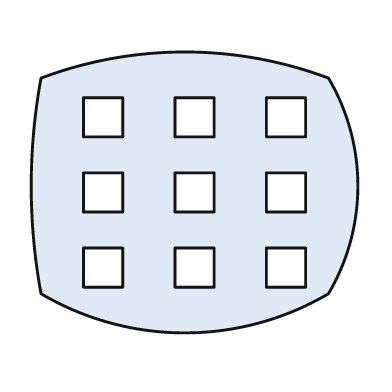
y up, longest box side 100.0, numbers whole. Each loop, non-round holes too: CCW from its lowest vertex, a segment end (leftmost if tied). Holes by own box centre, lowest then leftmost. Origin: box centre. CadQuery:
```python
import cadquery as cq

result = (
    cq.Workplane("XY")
    .moveTo(-47.0, -31.0)
    .threePointArc((-3.0, -43.0), (41.0, -31.0))
    .threePointArc((50.0, 2.0), (41.0, 35.0))
    .threePointArc((-3.0, 43.0), (-47.0, 35.0))
    .threePointArc((-50.0, 2.0), (-47.0, -31.0))
    .close()
    .moveTo(-34.0, -29.0)
    .lineTo(-22.0, -29.0)
    .lineTo(-22.0, -17.0)
    .lineTo(-34.0, -17.0)
    .close()
    .moveTo(-6.0, -29.0)
    .lineTo(6.0, -29.0)
    .lineTo(6.0, -17.0)
    .lineTo(-6.0, -17.0)
    .close()
    .moveTo(22.0, -29.0)
    .lineTo(34.0, -29.0)
    .lineTo(34.0, -17.0)
    .lineTo(22.0, -17.0)
    .close()
    .moveTo(-34.0, -6.0)
    .lineTo(-22.0, -6.0)
    .lineTo(-22.0, 6.0)
    .lineTo(-34.0, 6.0)
    .close()
    .moveTo(-6.0, -6.0)
    .lineTo(6.0, -6.0)
    .lineTo(6.0, 6.0)
    .lineTo(-6.0, 6.0)
    .close()
    .moveTo(22.0, -6.0)
    .lineTo(34.0, -6.0)
    .lineTo(34.0, 6.0)
    .lineTo(22.0, 6.0)
    .close()
    .moveTo(-34.0, 17.0)
    .lineTo(-22.0, 17.0)
    .lineTo(-22.0, 29.0)
    .lineTo(-34.0, 29.0)
    .close()
    .moveTo(-6.0, 17.0)
    .lineTo(6.0, 17.0)
    .lineTo(6.0, 29.0)
    .lineTo(-6.0, 29.0)
    .close()
    .moveTo(22.0, 17.0)
    .lineTo(34.0, 17.0)
    .lineTo(34.0, 29.0)
    .lineTo(22.0, 29.0)
    .close()
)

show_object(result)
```